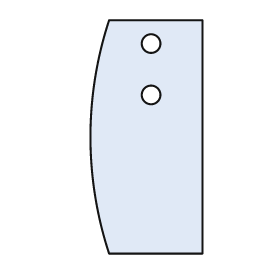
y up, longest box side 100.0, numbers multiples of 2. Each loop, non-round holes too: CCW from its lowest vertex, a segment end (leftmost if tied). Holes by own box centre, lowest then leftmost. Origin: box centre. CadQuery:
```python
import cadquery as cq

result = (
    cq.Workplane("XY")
    .moveTo(-16.0, -50.0)
    .lineTo(24.0, -50.0)
    .lineTo(24.0, 50.0)
    .lineTo(-16.0, 50.0)
    .threePointArc((-24.0, 0.0), (-16.0, -50.0))
    .close()
    .moveTo(2.0, 18.0)
    .circle(4.0)
    .moveTo(2.0, 40.0)
    .circle(4.0)
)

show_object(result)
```